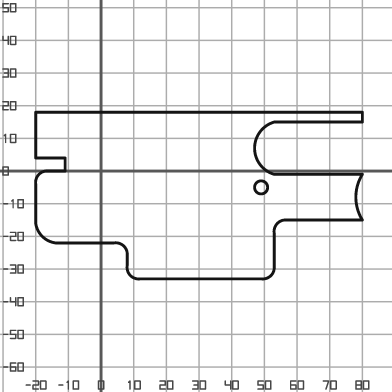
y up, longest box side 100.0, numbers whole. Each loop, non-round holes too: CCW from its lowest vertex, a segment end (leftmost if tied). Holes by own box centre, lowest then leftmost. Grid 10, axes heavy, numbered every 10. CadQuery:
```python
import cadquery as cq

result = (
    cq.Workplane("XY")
    .moveTo(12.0, -33.0)
    .lineTo(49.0, -33.0)
    .threePointArc((52.0, -32.0), (53.0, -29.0))
    .lineTo(53.0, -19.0)
    .threePointArc((54.0, -16.0), (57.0, -15.0))
    .lineTo(80.0, -15.0)
    .threePointArc((78.0, -8.0), (80.0, -1.0))
    .lineTo(53.0, -1.0)
    .threePointArc((47.0, 7.0), (53.0, 15.0))
    .lineTo(80.0, 15.0)
    .lineTo(80.0, 18.0)
    .lineTo(-20.0, 18.0)
    .lineTo(-20.0, 4.0)
    .lineTo(-11.0, 4.0)
    .lineTo(-11.0, 0.0)
    .lineTo(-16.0, 0.0)
    .threePointArc((-19.0, -1.0), (-20.0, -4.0))
    .lineTo(-20.0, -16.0)
    .threePointArc((-18.0, -20.0), (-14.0, -22.0))
    .lineTo(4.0, -22.0)
    .threePointArc((7.0, -23.0), (8.0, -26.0))
    .lineTo(8.0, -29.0)
    .threePointArc((9.0, -32.0), (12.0, -33.0))
    .close()
    .moveTo(49.0, -5.0)
    .circle(2.0)
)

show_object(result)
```